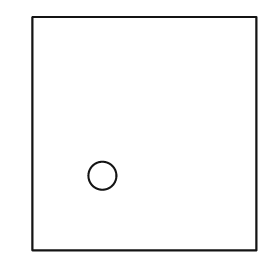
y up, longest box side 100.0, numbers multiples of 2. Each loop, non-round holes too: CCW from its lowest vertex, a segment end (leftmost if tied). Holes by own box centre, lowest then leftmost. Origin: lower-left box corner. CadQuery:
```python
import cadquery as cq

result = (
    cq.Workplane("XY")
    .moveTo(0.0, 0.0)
    .lineTo(96.0, 0.0)
    .lineTo(96.0, 100.0)
    .lineTo(0.0, 100.0)
    .close()
    .moveTo(30.0, 32.0)
    .circle(6.0)
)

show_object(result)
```